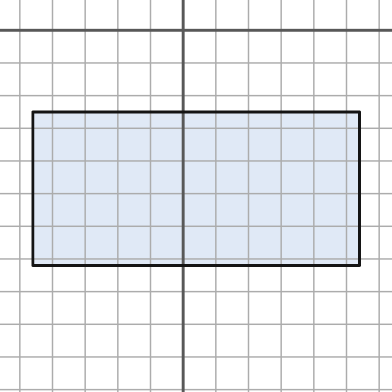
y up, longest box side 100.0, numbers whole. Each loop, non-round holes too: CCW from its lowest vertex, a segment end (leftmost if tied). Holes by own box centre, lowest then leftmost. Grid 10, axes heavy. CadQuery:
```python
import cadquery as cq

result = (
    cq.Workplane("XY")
    .moveTo(-46.0, -72.0)
    .lineTo(54.0, -72.0)
    .lineTo(54.0, -25.0)
    .lineTo(-46.0, -25.0)
    .close()
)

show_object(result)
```